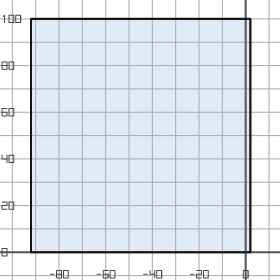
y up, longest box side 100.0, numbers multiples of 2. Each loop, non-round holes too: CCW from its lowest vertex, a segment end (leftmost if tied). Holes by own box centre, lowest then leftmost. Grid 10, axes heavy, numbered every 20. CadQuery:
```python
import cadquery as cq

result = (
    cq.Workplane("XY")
    .moveTo(-92.0, 0.0)
    .lineTo(2.0, 0.0)
    .lineTo(2.0, 100.0)
    .lineTo(-92.0, 100.0)
    .close()
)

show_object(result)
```